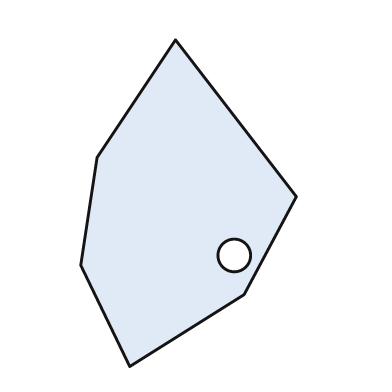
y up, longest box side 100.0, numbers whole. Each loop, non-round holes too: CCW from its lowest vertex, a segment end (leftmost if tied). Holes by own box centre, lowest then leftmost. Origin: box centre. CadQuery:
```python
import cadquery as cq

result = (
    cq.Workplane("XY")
    .moveTo(-18.0, -50.0)
    .lineTo(17.0, -28.0)
    .lineTo(33.0, 2.0)
    .lineTo(-4.0, 50.0)
    .lineTo(-28.0, 14.0)
    .lineTo(-33.0, -19.0)
    .close()
    .moveTo(14.0, -16.0)
    .circle(5.0)
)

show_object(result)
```